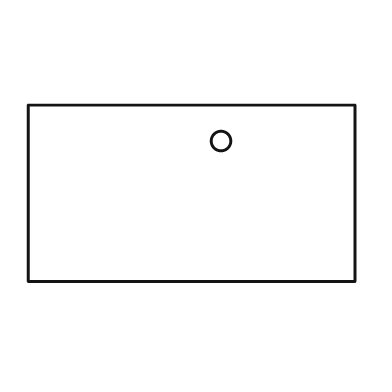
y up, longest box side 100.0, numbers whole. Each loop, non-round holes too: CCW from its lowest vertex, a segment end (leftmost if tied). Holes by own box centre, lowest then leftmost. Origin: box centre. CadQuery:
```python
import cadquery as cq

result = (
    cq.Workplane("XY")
    .moveTo(-50.0, -27.0)
    .lineTo(50.0, -27.0)
    .lineTo(50.0, 27.0)
    .lineTo(-50.0, 27.0)
    .close()
    .moveTo(9.0, 16.0)
    .circle(3.0)
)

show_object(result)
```